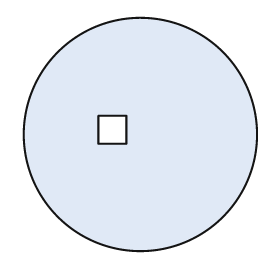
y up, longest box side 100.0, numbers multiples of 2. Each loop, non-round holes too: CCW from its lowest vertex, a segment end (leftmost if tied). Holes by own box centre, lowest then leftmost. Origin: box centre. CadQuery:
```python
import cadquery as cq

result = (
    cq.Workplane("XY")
    .moveTo(0.0, 0.0)
    .circle(50.0)
    .moveTo(-18.0, -4.0)
    .lineTo(-6.0, -4.0)
    .lineTo(-6.0, 8.0)
    .lineTo(-18.0, 8.0)
    .close()
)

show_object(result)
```